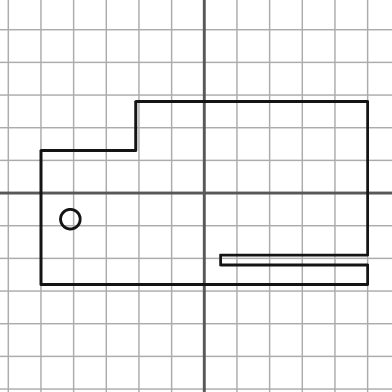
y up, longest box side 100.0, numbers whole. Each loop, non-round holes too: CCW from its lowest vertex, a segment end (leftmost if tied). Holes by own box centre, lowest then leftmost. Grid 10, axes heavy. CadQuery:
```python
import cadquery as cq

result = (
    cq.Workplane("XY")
    .moveTo(-50.0, -28.0)
    .lineTo(50.0, -28.0)
    .lineTo(50.0, -22.0)
    .lineTo(5.0, -22.0)
    .lineTo(5.0, -19.0)
    .lineTo(50.0, -19.0)
    .lineTo(50.0, 28.0)
    .lineTo(-21.0, 28.0)
    .lineTo(-21.0, 13.0)
    .lineTo(-50.0, 13.0)
    .close()
    .moveTo(-41.0, -8.0)
    .circle(3.0)
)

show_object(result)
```